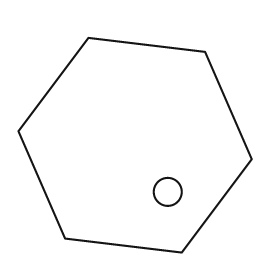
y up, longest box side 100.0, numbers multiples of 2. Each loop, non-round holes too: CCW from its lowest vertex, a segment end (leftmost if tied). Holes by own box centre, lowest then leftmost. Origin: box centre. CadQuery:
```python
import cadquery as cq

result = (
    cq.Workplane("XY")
    .moveTo(20.0, -46.0)
    .lineTo(50.0, -6.0)
    .lineTo(30.0, 40.0)
    .lineTo(-20.0, 46.0)
    .lineTo(-50.0, 6.0)
    .lineTo(-30.0, -40.0)
    .close()
    .moveTo(14.0, -20.0)
    .circle(6.0)
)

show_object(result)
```